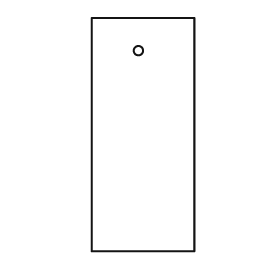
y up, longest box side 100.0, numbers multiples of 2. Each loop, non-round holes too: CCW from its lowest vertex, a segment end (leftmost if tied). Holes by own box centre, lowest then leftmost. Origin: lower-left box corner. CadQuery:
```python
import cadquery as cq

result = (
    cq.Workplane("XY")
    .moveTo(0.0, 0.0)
    .lineTo(44.0, 0.0)
    .lineTo(44.0, 100.0)
    .lineTo(0.0, 100.0)
    .close()
    .moveTo(20.0, 86.0)
    .circle(2.0)
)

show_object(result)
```